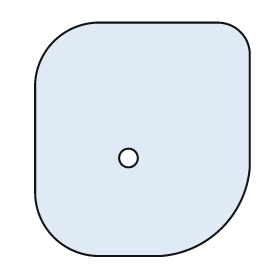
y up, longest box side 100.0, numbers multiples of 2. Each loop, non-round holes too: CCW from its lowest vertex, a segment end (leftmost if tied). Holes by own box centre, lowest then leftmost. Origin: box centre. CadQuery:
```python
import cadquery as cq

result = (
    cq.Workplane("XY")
    .moveTo(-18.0, -50.0)
    .lineTo(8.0, -50.0)
    .threePointArc((34.0, -38.0), (46.0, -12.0))
    .lineTo(46.0, 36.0)
    .threePointArc((42.0, 46.0), (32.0, 50.0))
    .lineTo(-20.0, 50.0)
    .threePointArc((-38.0, 42.0), (-46.0, 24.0))
    .lineTo(-46.0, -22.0)
    .threePointArc((-38.0, -42.0), (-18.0, -50.0))
    .close()
    .moveTo(-6.0, -8.0)
    .circle(4.0)
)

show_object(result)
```